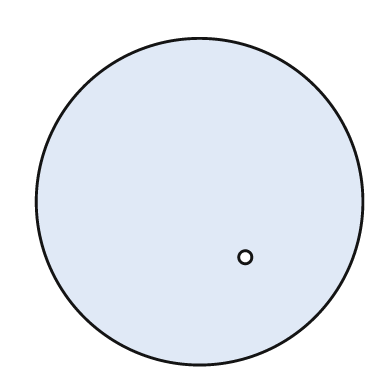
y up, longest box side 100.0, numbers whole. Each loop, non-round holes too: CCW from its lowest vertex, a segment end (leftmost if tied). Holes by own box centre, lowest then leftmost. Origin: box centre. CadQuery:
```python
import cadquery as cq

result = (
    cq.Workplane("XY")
    .moveTo(0.0, 0.0)
    .circle(50.0)
    .moveTo(14.0, -17.0)
    .circle(2.0)
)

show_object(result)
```